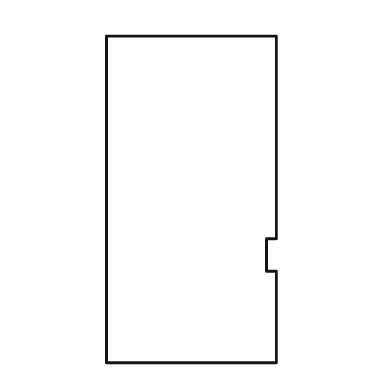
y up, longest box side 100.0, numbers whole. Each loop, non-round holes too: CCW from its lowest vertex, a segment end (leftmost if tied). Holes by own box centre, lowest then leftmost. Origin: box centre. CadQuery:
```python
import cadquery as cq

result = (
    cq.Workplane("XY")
    .moveTo(-26.0, -50.0)
    .lineTo(26.0, -50.0)
    .lineTo(26.0, -22.0)
    .lineTo(23.0, -22.0)
    .lineTo(23.0, -12.0)
    .lineTo(26.0, -12.0)
    .lineTo(26.0, 50.0)
    .lineTo(-26.0, 50.0)
    .close()
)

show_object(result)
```